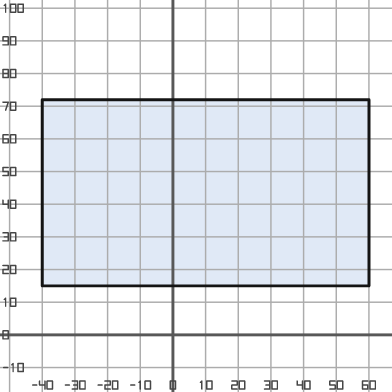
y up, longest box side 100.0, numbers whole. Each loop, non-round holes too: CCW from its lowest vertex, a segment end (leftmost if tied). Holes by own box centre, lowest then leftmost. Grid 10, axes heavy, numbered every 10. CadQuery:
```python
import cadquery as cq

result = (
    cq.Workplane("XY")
    .moveTo(-40.0, 15.0)
    .lineTo(60.0, 15.0)
    .lineTo(60.0, 72.0)
    .lineTo(-40.0, 72.0)
    .close()
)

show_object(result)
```